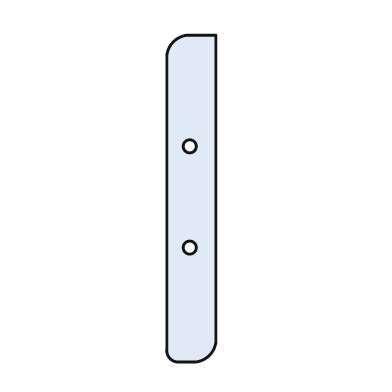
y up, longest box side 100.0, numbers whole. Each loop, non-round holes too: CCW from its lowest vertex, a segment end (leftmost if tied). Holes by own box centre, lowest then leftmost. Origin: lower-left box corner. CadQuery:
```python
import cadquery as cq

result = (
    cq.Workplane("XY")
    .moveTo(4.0, 0.0)
    .lineTo(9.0, 0.0)
    .threePointArc((13.0, 2.0), (15.0, 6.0))
    .lineTo(15.0, 100.0)
    .lineTo(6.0, 100.0)
    .threePointArc((2.0, 98.0), (0.0, 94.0))
    .lineTo(0.0, 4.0)
    .threePointArc((1.0, 1.0), (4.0, 0.0))
    .close()
    .moveTo(7.0, 35.0)
    .circle(2.0)
    .moveTo(7.0, 66.0)
    .circle(2.0)
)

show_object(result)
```